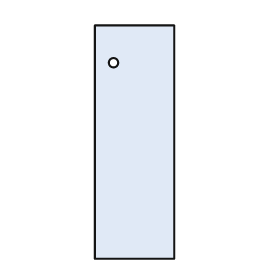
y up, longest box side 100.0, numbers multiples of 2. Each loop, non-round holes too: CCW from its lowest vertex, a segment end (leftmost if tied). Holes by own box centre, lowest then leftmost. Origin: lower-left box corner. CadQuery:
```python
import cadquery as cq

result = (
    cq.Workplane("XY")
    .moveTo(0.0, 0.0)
    .lineTo(34.0, 0.0)
    .lineTo(34.0, 100.0)
    .lineTo(0.0, 100.0)
    .close()
    .moveTo(8.0, 84.0)
    .circle(2.0)
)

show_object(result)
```